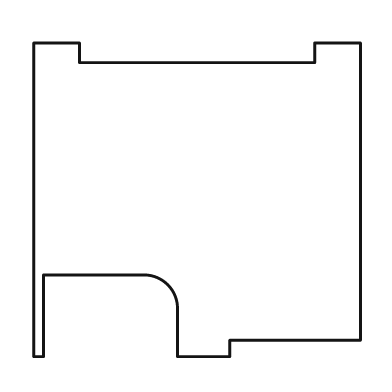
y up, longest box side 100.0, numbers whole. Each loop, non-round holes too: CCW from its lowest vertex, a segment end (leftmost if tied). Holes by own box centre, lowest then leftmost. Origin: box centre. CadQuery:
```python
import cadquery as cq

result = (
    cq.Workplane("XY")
    .moveTo(-50.0, -48.0)
    .lineTo(-47.0, -48.0)
    .lineTo(-47.0, -23.0)
    .lineTo(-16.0, -23.0)
    .threePointArc((-9.0, -26.0), (-6.0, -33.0))
    .lineTo(-6.0, -48.0)
    .lineTo(10.0, -48.0)
    .lineTo(10.0, -43.0)
    .lineTo(50.0, -43.0)
    .lineTo(50.0, 48.0)
    .lineTo(36.0, 48.0)
    .lineTo(36.0, 42.0)
    .lineTo(-36.0, 42.0)
    .lineTo(-36.0, 48.0)
    .lineTo(-50.0, 48.0)
    .close()
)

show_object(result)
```